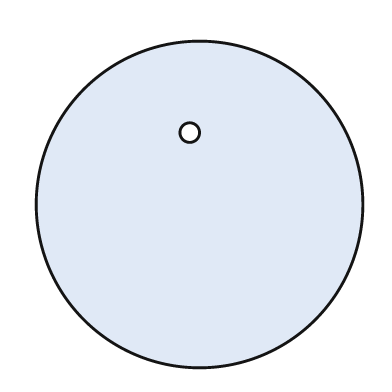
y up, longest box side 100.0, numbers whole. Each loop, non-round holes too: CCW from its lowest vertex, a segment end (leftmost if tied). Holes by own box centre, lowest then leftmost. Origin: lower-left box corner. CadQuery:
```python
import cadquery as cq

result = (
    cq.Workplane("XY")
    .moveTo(50.0, 50.0)
    .circle(50.0)
    .moveTo(47.0, 72.0)
    .circle(3.0)
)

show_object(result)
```